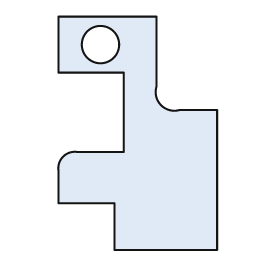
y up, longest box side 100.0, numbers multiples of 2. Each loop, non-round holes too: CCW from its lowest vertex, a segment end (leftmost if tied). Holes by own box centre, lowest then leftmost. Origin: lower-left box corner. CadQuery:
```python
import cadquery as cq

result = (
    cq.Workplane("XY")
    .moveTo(24.0, 0.0)
    .lineTo(68.0, 0.0)
    .lineTo(68.0, 60.0)
    .lineTo(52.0, 60.0)
    .threePointArc((44.0, 62.0), (42.0, 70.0))
    .lineTo(42.0, 100.0)
    .lineTo(0.0, 100.0)
    .lineTo(0.0, 76.0)
    .lineTo(28.0, 76.0)
    .lineTo(28.0, 42.0)
    .lineTo(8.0, 42.0)
    .threePointArc((2.0, 40.0), (0.0, 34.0))
    .lineTo(0.0, 20.0)
    .lineTo(24.0, 20.0)
    .close()
    .moveTo(18.0, 88.0)
    .circle(8.0)
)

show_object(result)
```